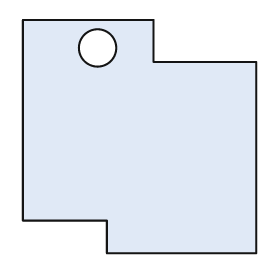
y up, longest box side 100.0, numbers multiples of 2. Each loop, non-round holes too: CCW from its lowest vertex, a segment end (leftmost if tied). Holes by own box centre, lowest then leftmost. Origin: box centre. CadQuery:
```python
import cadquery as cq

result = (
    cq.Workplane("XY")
    .moveTo(-14.0, -50.0)
    .lineTo(50.0, -50.0)
    .lineTo(50.0, 32.0)
    .lineTo(6.0, 32.0)
    .lineTo(6.0, 50.0)
    .lineTo(-50.0, 50.0)
    .lineTo(-50.0, -36.0)
    .lineTo(-14.0, -36.0)
    .close()
    .moveTo(-18.0, 38.0)
    .circle(8.0)
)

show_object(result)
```